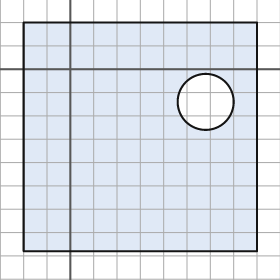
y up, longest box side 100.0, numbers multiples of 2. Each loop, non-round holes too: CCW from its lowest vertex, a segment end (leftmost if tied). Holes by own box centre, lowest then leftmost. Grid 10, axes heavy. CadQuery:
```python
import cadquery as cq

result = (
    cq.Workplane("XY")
    .moveTo(-20.0, -78.0)
    .lineTo(80.0, -78.0)
    .lineTo(80.0, 20.0)
    .lineTo(-20.0, 20.0)
    .close()
    .moveTo(58.0, -14.0)
    .circle(12.0)
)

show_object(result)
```